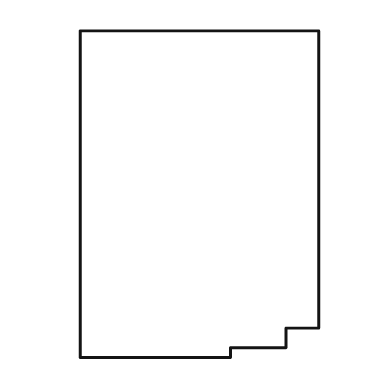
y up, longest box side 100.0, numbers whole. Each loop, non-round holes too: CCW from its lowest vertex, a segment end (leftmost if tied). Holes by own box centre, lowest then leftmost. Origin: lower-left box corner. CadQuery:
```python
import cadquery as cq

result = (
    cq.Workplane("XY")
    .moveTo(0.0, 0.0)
    .lineTo(46.0, 0.0)
    .lineTo(46.0, 3.0)
    .lineTo(63.0, 3.0)
    .lineTo(63.0, 9.0)
    .lineTo(73.0, 9.0)
    .lineTo(73.0, 100.0)
    .lineTo(0.0, 100.0)
    .close()
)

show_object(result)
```